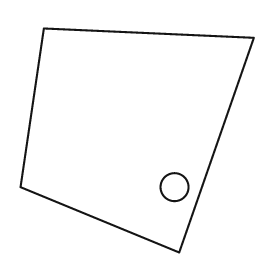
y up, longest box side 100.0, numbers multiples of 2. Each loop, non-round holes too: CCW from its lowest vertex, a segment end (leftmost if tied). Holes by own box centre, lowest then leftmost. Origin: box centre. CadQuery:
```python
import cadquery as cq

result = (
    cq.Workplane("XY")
    .moveTo(18.0, -48.0)
    .lineTo(50.0, 44.0)
    .lineTo(-40.0, 48.0)
    .lineTo(-50.0, -20.0)
    .close()
    .moveTo(16.0, -20.0)
    .circle(6.0)
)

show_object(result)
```